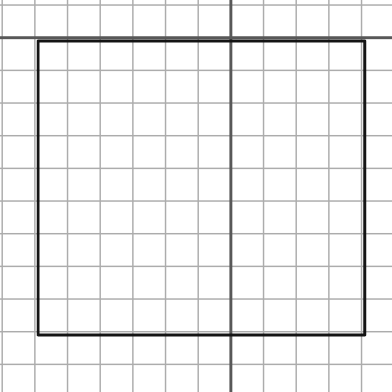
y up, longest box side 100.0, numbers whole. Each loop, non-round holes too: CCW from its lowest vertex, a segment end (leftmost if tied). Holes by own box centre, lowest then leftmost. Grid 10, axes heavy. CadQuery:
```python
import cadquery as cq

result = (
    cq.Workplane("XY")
    .moveTo(-59.0, -91.0)
    .lineTo(41.0, -91.0)
    .lineTo(41.0, -1.0)
    .lineTo(-59.0, -1.0)
    .close()
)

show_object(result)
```